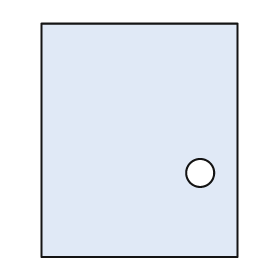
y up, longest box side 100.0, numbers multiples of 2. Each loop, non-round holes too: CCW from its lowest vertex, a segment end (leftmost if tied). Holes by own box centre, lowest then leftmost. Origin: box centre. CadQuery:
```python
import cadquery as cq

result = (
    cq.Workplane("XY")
    .moveTo(-42.0, -50.0)
    .lineTo(42.0, -50.0)
    .lineTo(42.0, 50.0)
    .lineTo(-42.0, 50.0)
    .close()
    .moveTo(26.0, -14.0)
    .circle(6.0)
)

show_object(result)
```